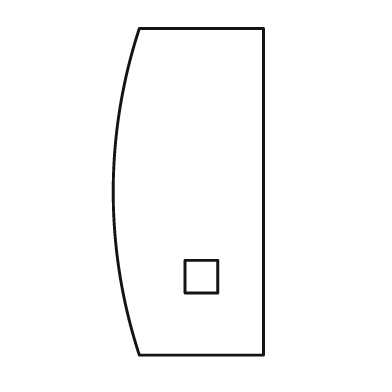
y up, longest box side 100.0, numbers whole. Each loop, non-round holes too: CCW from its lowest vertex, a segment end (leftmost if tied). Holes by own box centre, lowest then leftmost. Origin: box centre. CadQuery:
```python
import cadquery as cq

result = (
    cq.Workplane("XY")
    .moveTo(-15.0, -50.0)
    .lineTo(23.0, -50.0)
    .lineTo(23.0, 50.0)
    .lineTo(-15.0, 50.0)
    .threePointArc((-23.0, 0.0), (-15.0, -50.0))
    .close()
    .moveTo(-1.0, -31.0)
    .lineTo(9.0, -31.0)
    .lineTo(9.0, -21.0)
    .lineTo(-1.0, -21.0)
    .close()
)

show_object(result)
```